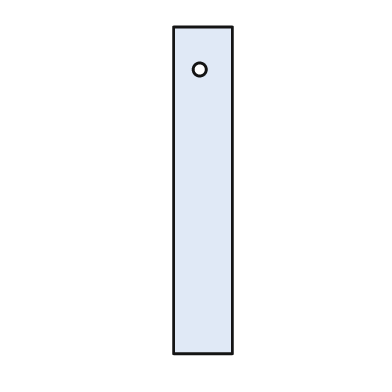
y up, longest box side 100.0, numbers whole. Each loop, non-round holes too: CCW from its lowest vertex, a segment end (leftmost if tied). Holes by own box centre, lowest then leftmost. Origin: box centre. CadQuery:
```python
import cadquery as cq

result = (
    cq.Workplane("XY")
    .moveTo(-9.0, -50.0)
    .lineTo(9.0, -50.0)
    .lineTo(9.0, 50.0)
    .lineTo(-9.0, 50.0)
    .close()
    .moveTo(-1.0, 37.0)
    .circle(2.0)
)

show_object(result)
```